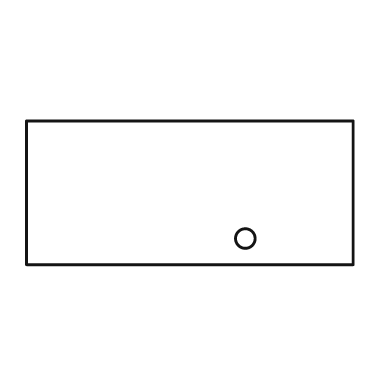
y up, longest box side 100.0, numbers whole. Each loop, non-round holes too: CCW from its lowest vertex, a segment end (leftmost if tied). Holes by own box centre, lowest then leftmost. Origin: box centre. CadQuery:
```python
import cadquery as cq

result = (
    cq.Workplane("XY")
    .moveTo(-50.0, -22.0)
    .lineTo(50.0, -22.0)
    .lineTo(50.0, 22.0)
    .lineTo(-50.0, 22.0)
    .close()
    .moveTo(17.0, -14.0)
    .circle(3.0)
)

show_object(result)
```